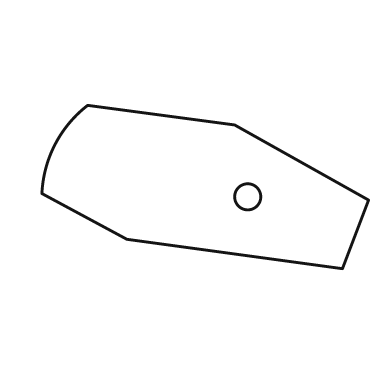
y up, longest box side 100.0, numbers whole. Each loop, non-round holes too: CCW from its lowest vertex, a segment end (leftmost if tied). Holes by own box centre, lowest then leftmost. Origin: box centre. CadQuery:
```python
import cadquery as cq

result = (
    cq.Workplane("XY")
    .moveTo(42.0, -25.0)
    .lineTo(50.0, -4.0)
    .lineTo(9.0, 19.0)
    .lineTo(-36.0, 25.0)
    .threePointArc((-46.0, 13.0), (-50.0, -2.0))
    .lineTo(-24.0, -16.0)
    .close()
    .moveTo(13.0, -3.0)
    .circle(4.0)
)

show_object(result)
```